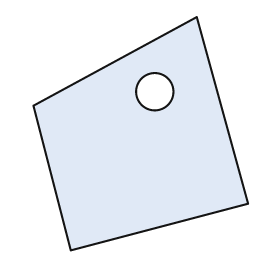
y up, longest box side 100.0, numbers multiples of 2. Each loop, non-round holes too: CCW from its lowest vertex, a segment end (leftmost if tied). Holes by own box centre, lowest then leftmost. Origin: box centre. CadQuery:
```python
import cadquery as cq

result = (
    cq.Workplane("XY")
    .moveTo(-30.0, -50.0)
    .lineTo(46.0, -30.0)
    .lineTo(24.0, 50.0)
    .lineTo(-46.0, 12.0)
    .close()
    .moveTo(6.0, 18.0)
    .circle(8.0)
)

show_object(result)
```